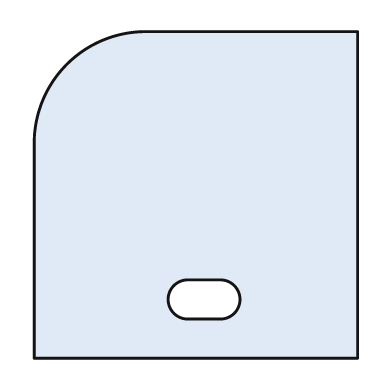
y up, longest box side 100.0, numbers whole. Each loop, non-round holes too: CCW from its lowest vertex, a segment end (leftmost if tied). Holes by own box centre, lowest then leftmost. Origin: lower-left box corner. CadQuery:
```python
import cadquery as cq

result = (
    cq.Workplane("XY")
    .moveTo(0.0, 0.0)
    .lineTo(99.0, 0.0)
    .lineTo(99.0, 100.0)
    .lineTo(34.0, 100.0)
    .threePointArc((10.0, 90.0), (0.0, 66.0))
    .close()
    .moveTo(47.0, 12.0)
    .lineTo(57.0, 12.0)
    .threePointArc((63.0, 18.0), (57.0, 24.0))
    .lineTo(47.0, 24.0)
    .threePointArc((41.0, 18.0), (47.0, 12.0))
    .close()
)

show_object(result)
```